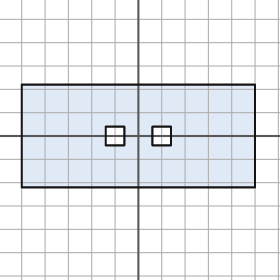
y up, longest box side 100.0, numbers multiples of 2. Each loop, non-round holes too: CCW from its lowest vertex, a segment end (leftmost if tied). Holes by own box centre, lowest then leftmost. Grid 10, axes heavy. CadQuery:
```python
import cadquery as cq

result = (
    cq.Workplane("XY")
    .moveTo(-50.0, -22.0)
    .lineTo(50.0, -22.0)
    .lineTo(50.0, 22.0)
    .lineTo(-50.0, 22.0)
    .close()
    .moveTo(-14.0, -4.0)
    .lineTo(-6.0, -4.0)
    .lineTo(-6.0, 4.0)
    .lineTo(-14.0, 4.0)
    .close()
    .moveTo(6.0, -4.0)
    .lineTo(14.0, -4.0)
    .lineTo(14.0, 4.0)
    .lineTo(6.0, 4.0)
    .close()
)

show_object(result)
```